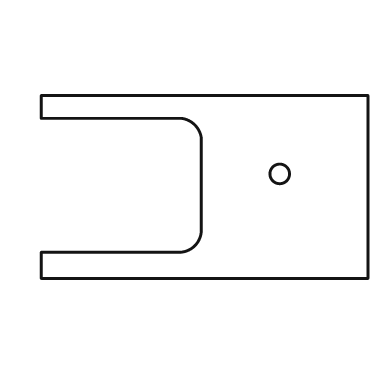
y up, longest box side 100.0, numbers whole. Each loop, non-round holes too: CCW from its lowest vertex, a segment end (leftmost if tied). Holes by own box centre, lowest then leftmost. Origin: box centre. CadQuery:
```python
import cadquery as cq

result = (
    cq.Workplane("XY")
    .moveTo(-50.0, -28.0)
    .lineTo(50.0, -28.0)
    .lineTo(50.0, 28.0)
    .lineTo(-50.0, 28.0)
    .lineTo(-50.0, 21.0)
    .lineTo(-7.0, 21.0)
    .threePointArc((-3.0, 19.0), (-1.0, 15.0))
    .lineTo(-1.0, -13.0)
    .threePointArc((-3.0, -18.0), (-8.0, -20.0))
    .lineTo(-50.0, -20.0)
    .close()
    .moveTo(23.0, 4.0)
    .circle(3.0)
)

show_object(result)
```